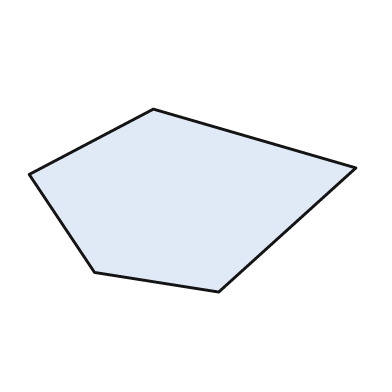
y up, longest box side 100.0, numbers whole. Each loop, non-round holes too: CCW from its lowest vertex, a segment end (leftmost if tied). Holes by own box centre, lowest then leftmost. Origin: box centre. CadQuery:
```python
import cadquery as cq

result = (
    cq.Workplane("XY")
    .moveTo(8.0, -28.0)
    .lineTo(50.0, 10.0)
    .lineTo(-12.0, 28.0)
    .lineTo(-50.0, 8.0)
    .lineTo(-30.0, -22.0)
    .close()
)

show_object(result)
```